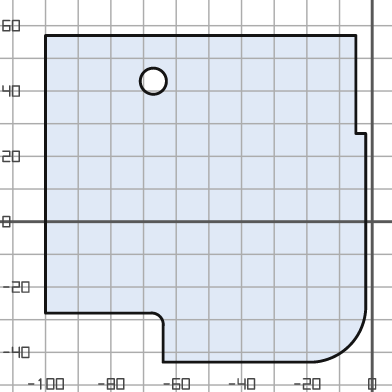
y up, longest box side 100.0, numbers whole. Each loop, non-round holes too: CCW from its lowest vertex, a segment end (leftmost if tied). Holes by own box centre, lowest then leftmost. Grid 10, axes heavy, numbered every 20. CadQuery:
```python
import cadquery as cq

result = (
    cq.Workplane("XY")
    .moveTo(-64.0, -43.0)
    .lineTo(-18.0, -43.0)
    .threePointArc((-7.0, -38.0), (-2.0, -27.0))
    .lineTo(-2.0, 27.0)
    .lineTo(-5.0, 27.0)
    .lineTo(-5.0, 57.0)
    .lineTo(-100.0, 57.0)
    .lineTo(-100.0, -28.0)
    .lineTo(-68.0, -28.0)
    .threePointArc((-65.0, -29.0), (-64.0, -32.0))
    .close()
    .moveTo(-67.0, 43.0)
    .circle(4.0)
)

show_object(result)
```